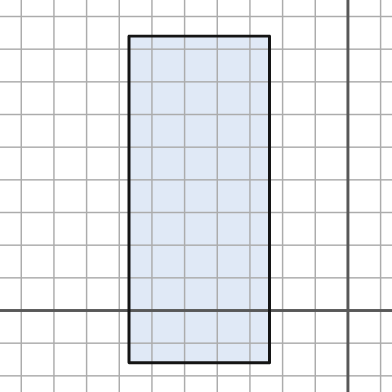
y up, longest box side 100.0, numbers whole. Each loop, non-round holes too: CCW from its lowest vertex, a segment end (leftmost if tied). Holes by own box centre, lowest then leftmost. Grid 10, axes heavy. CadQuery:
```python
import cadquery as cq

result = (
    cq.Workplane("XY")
    .moveTo(-67.0, -16.0)
    .lineTo(-24.0, -16.0)
    .lineTo(-24.0, 84.0)
    .lineTo(-67.0, 84.0)
    .close()
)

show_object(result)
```